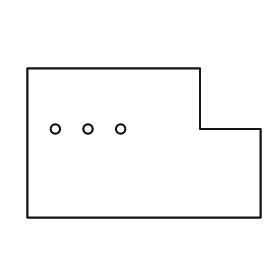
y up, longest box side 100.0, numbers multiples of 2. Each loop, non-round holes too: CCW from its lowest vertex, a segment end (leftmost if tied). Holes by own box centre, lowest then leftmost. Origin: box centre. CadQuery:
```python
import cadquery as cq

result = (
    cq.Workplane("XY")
    .moveTo(-50.0, -32.0)
    .lineTo(50.0, -32.0)
    .lineTo(50.0, 6.0)
    .lineTo(24.0, 6.0)
    .lineTo(24.0, 32.0)
    .lineTo(-50.0, 32.0)
    .close()
    .moveTo(-38.0, 6.0)
    .circle(2.0)
    .moveTo(-24.0, 6.0)
    .circle(2.0)
    .moveTo(-10.0, 6.0)
    .circle(2.0)
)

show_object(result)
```